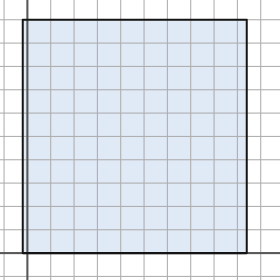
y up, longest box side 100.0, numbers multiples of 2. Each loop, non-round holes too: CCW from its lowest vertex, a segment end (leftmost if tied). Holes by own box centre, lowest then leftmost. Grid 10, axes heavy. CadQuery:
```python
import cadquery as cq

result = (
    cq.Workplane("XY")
    .moveTo(-2.0, 0.0)
    .lineTo(94.0, 0.0)
    .lineTo(94.0, 100.0)
    .lineTo(-2.0, 100.0)
    .close()
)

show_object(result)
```